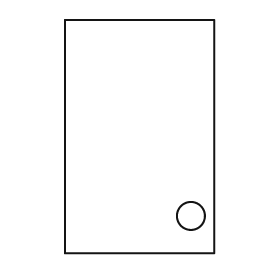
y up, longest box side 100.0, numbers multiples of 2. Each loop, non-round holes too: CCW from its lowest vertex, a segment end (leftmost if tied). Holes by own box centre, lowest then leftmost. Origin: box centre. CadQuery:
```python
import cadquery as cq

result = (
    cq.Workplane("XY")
    .moveTo(-32.0, -50.0)
    .lineTo(32.0, -50.0)
    .lineTo(32.0, 50.0)
    .lineTo(-32.0, 50.0)
    .close()
    .moveTo(22.0, -34.0)
    .circle(6.0)
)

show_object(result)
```